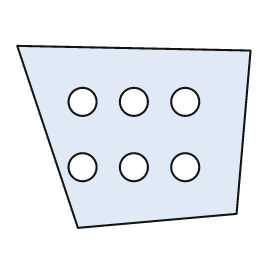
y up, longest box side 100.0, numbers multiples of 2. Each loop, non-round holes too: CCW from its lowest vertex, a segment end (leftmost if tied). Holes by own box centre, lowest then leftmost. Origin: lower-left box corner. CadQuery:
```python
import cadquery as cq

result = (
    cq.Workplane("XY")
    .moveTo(26.0, 0.0)
    .lineTo(94.0, 6.0)
    .lineTo(100.0, 76.0)
    .lineTo(0.0, 78.0)
    .close()
    .moveTo(28.0, 26.0)
    .circle(6.0)
    .moveTo(50.0, 26.0)
    .circle(6.0)
    .moveTo(72.0, 26.0)
    .circle(6.0)
    .moveTo(28.0, 54.0)
    .circle(6.0)
    .moveTo(50.0, 54.0)
    .circle(6.0)
    .moveTo(72.0, 54.0)
    .circle(6.0)
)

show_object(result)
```